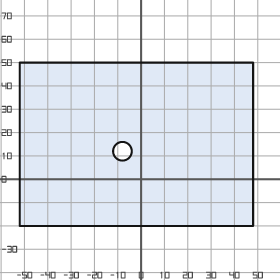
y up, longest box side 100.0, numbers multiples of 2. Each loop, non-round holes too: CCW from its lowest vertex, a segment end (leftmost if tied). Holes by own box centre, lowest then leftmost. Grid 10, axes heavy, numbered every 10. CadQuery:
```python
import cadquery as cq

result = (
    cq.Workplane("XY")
    .moveTo(-52.0, -20.0)
    .lineTo(48.0, -20.0)
    .lineTo(48.0, 50.0)
    .lineTo(-52.0, 50.0)
    .close()
    .moveTo(-8.0, 12.0)
    .circle(4.0)
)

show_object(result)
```